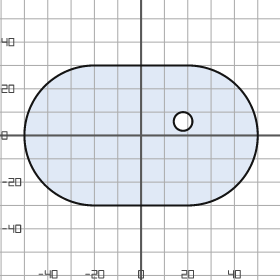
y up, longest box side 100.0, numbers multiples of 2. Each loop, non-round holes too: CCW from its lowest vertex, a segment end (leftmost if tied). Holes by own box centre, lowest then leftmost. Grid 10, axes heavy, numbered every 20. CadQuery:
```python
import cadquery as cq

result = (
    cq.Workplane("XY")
    .moveTo(-20.0, -30.0)
    .lineTo(20.0, -30.0)
    .threePointArc((50.0, 0.0), (20.0, 30.0))
    .lineTo(-20.0, 30.0)
    .threePointArc((-50.0, 0.0), (-20.0, -30.0))
    .close()
    .moveTo(18.0, 6.0)
    .circle(4.0)
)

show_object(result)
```